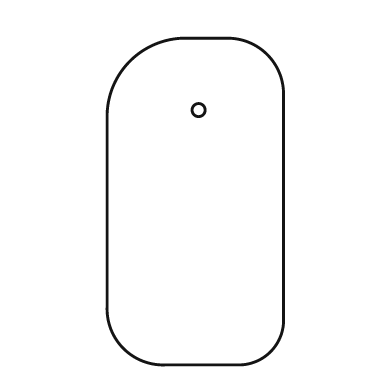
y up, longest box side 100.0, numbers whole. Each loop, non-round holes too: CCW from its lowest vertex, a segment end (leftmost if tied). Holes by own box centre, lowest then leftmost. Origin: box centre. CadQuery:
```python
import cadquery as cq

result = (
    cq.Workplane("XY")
    .moveTo(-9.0, -50.0)
    .lineTo(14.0, -50.0)
    .threePointArc((23.0, -46.0), (27.0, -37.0))
    .lineTo(27.0, 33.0)
    .threePointArc((22.0, 45.0), (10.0, 50.0))
    .lineTo(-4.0, 50.0)
    .threePointArc((-20.0, 43.0), (-27.0, 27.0))
    .lineTo(-27.0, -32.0)
    .threePointArc((-22.0, -45.0), (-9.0, -50.0))
    .close()
    .moveTo(1.0, 28.0)
    .circle(2.0)
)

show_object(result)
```